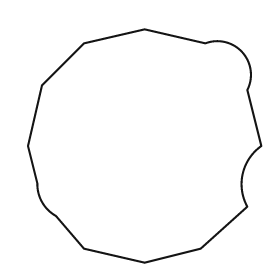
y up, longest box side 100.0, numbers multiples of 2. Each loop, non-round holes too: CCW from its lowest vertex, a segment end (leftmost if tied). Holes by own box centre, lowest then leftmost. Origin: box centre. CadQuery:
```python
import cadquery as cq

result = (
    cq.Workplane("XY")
    .moveTo(0.0, -50.0)
    .lineTo(24.0, -44.0)
    .lineTo(44.0, -26.0)
    .threePointArc((42.0, -12.0), (50.0, 0.0))
    .lineTo(44.0, 24.0)
    .threePointArc((42.0, 40.0), (26.0, 44.0))
    .lineTo(0.0, 50.0)
    .lineTo(-26.0, 44.0)
    .lineTo(-44.0, 26.0)
    .lineTo(-50.0, 0.0)
    .lineTo(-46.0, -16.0)
    .threePointArc((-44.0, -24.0), (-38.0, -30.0))
    .lineTo(-26.0, -44.0)
    .close()
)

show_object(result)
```